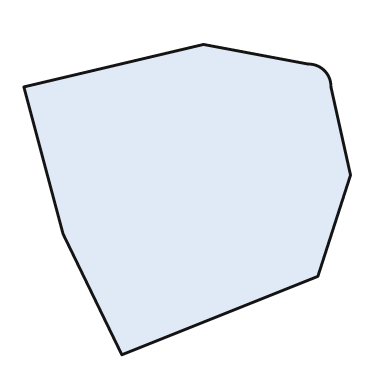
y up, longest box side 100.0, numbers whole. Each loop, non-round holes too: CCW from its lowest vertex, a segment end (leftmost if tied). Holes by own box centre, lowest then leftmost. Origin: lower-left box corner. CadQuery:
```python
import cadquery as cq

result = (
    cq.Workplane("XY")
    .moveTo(30.0, 0.0)
    .lineTo(90.0, 24.0)
    .lineTo(100.0, 55.0)
    .lineTo(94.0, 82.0)
    .threePointArc((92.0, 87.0), (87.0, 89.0))
    .lineTo(55.0, 95.0)
    .lineTo(0.0, 82.0)
    .lineTo(12.0, 37.0)
    .close()
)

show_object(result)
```